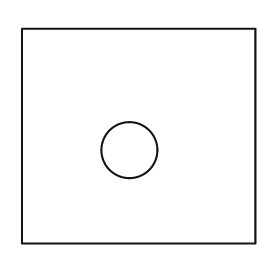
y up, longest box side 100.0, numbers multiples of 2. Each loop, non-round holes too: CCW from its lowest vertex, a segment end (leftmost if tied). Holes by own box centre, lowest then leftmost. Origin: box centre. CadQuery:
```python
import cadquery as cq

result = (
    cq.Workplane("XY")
    .moveTo(-50.0, -46.0)
    .lineTo(50.0, -46.0)
    .lineTo(50.0, 46.0)
    .lineTo(-50.0, 46.0)
    .close()
    .moveTo(-4.0, -6.0)
    .circle(12.0)
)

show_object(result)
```